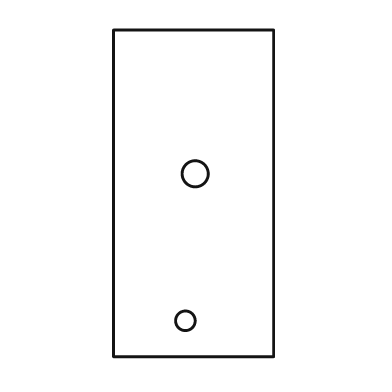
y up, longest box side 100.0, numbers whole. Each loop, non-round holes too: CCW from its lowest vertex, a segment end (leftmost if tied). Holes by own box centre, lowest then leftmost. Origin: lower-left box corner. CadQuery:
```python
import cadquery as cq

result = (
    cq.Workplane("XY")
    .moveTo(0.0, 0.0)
    .lineTo(49.0, 0.0)
    .lineTo(49.0, 100.0)
    .lineTo(0.0, 100.0)
    .close()
    .moveTo(22.0, 11.0)
    .circle(3.0)
    .moveTo(25.0, 56.0)
    .circle(4.0)
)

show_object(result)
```